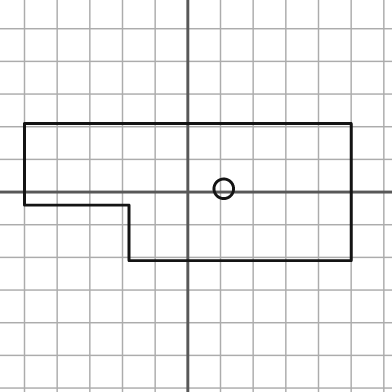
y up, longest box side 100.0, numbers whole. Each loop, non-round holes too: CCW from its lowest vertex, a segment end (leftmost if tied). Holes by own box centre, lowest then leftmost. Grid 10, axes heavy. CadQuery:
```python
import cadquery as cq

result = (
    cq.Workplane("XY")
    .moveTo(-18.0, -21.0)
    .lineTo(50.0, -21.0)
    .lineTo(50.0, 21.0)
    .lineTo(-50.0, 21.0)
    .lineTo(-50.0, -4.0)
    .lineTo(-18.0, -4.0)
    .close()
    .moveTo(11.0, 1.0)
    .circle(3.0)
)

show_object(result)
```